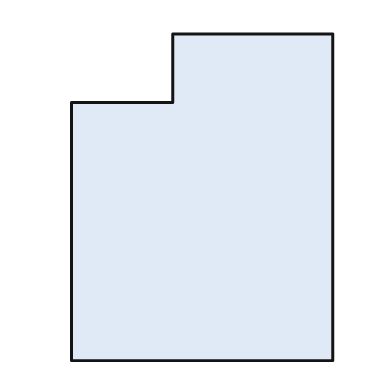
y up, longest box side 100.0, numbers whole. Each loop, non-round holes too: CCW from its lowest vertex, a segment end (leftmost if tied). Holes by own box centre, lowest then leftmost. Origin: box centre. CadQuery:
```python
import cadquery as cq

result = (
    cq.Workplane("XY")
    .moveTo(-40.0, -50.0)
    .lineTo(40.0, -50.0)
    .lineTo(40.0, 50.0)
    .lineTo(-9.0, 50.0)
    .lineTo(-9.0, 29.0)
    .lineTo(-40.0, 29.0)
    .close()
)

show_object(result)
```